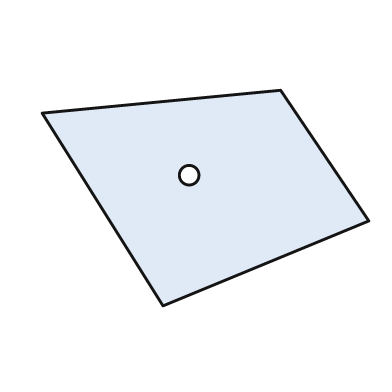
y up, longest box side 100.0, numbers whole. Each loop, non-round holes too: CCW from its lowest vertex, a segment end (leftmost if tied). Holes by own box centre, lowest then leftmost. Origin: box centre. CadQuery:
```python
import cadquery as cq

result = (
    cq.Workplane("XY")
    .moveTo(-13.0, -33.0)
    .lineTo(50.0, -7.0)
    .lineTo(23.0, 33.0)
    .lineTo(-50.0, 26.0)
    .close()
    .moveTo(-5.0, 7.0)
    .circle(3.0)
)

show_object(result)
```